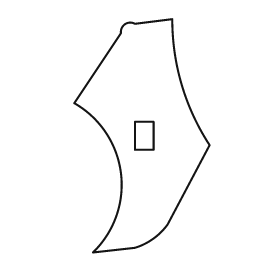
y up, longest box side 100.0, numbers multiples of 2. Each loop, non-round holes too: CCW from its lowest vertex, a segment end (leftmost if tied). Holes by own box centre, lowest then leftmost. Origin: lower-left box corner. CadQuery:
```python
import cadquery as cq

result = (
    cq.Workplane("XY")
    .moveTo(8.0, 0.0)
    .lineTo(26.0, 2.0)
    .threePointArc((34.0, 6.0), (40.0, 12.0))
    .lineTo(58.0, 46.0)
    .threePointArc((46.0, 72.0), (42.0, 100.0))
    .lineTo(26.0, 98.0)
    .threePointArc((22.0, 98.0), (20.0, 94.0))
    .lineTo(0.0, 64.0)
    .threePointArc((20.0, 34.0), (8.0, 0.0))
    .close()
    .moveTo(26.0, 44.0)
    .lineTo(34.0, 44.0)
    .lineTo(34.0, 56.0)
    .lineTo(26.0, 56.0)
    .close()
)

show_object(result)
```